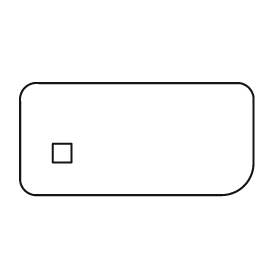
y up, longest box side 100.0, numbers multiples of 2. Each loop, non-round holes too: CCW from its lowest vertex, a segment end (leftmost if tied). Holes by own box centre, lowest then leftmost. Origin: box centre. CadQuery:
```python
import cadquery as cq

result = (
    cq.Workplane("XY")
    .moveTo(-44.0, -24.0)
    .lineTo(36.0, -24.0)
    .threePointArc((46.0, -20.0), (50.0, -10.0))
    .lineTo(50.0, 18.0)
    .threePointArc((48.0, 22.0), (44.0, 24.0))
    .lineTo(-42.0, 24.0)
    .threePointArc((-48.0, 22.0), (-50.0, 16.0))
    .lineTo(-50.0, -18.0)
    .threePointArc((-48.0, -22.0), (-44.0, -24.0))
    .close()
    .moveTo(-36.0, -10.0)
    .lineTo(-28.0, -10.0)
    .lineTo(-28.0, -2.0)
    .lineTo(-36.0, -2.0)
    .close()
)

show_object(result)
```